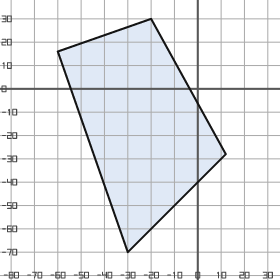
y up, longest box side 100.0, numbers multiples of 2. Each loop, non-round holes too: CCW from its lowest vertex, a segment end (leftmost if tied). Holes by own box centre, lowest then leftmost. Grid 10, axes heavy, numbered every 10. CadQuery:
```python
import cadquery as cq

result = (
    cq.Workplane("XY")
    .moveTo(-30.0, -70.0)
    .lineTo(12.0, -28.0)
    .lineTo(-20.0, 30.0)
    .lineTo(-60.0, 16.0)
    .close()
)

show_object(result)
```